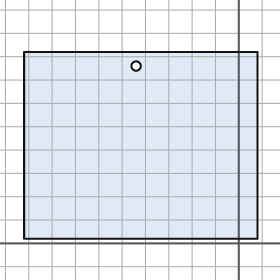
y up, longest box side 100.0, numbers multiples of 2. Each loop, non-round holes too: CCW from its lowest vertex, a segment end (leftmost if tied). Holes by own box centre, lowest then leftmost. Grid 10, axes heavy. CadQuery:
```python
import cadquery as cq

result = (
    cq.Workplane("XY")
    .moveTo(-92.0, 2.0)
    .lineTo(8.0, 2.0)
    .lineTo(8.0, 82.0)
    .lineTo(-92.0, 82.0)
    .close()
    .moveTo(-44.0, 76.0)
    .circle(2.0)
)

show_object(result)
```